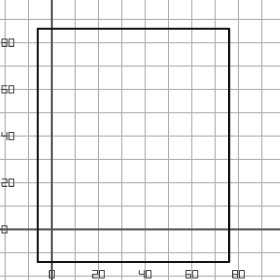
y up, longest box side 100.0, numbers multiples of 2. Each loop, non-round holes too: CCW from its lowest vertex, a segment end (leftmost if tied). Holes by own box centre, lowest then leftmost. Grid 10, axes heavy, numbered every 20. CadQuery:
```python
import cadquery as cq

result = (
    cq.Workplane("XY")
    .moveTo(-6.0, -14.0)
    .lineTo(76.0, -14.0)
    .lineTo(76.0, 86.0)
    .lineTo(-6.0, 86.0)
    .close()
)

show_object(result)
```